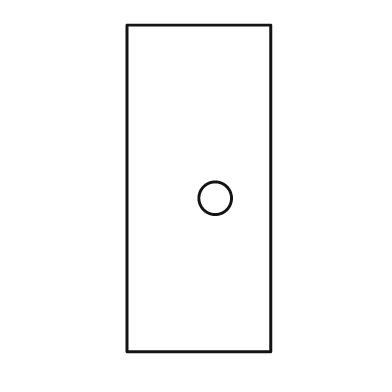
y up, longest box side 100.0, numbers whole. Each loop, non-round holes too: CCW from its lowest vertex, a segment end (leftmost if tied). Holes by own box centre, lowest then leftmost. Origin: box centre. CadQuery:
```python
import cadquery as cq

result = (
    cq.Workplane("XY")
    .moveTo(-22.0, -50.0)
    .lineTo(22.0, -50.0)
    .lineTo(22.0, 50.0)
    .lineTo(-22.0, 50.0)
    .close()
    .moveTo(5.0, -3.0)
    .circle(5.0)
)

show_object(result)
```